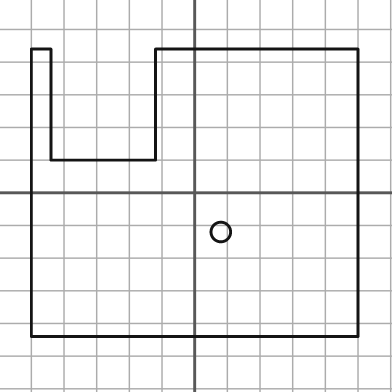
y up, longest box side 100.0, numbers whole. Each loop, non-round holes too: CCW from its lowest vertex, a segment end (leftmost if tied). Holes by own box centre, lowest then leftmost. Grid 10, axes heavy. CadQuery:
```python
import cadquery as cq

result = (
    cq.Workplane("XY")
    .moveTo(-50.0, -44.0)
    .lineTo(50.0, -44.0)
    .lineTo(50.0, 44.0)
    .lineTo(-12.0, 44.0)
    .lineTo(-12.0, 10.0)
    .lineTo(-44.0, 10.0)
    .lineTo(-44.0, 44.0)
    .lineTo(-50.0, 44.0)
    .close()
    .moveTo(8.0, -12.0)
    .circle(3.0)
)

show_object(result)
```